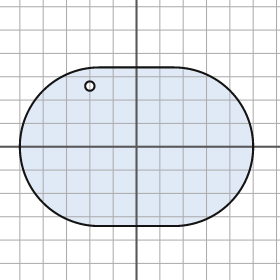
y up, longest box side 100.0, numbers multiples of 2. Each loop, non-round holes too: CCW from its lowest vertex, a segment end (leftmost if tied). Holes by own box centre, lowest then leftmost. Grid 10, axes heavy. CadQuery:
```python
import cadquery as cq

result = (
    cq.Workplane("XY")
    .moveTo(-16.0, -34.0)
    .lineTo(16.0, -34.0)
    .threePointArc((50.0, 0.0), (16.0, 34.0))
    .lineTo(-16.0, 34.0)
    .threePointArc((-50.0, 0.0), (-16.0, -34.0))
    .close()
    .moveTo(-20.0, 26.0)
    .circle(2.0)
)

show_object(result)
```